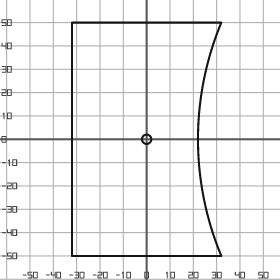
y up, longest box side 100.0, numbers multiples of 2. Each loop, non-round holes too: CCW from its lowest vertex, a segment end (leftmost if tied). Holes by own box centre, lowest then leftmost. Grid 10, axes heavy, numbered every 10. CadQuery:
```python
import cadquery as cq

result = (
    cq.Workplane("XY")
    .moveTo(-32.0, -50.0)
    .lineTo(32.0, -50.0)
    .threePointArc((22.0, 0.0), (32.0, 50.0))
    .lineTo(-32.0, 50.0)
    .close()
    .moveTo(0.0, 0.0)
    .circle(2.0)
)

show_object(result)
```